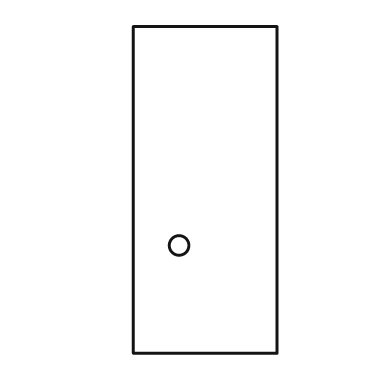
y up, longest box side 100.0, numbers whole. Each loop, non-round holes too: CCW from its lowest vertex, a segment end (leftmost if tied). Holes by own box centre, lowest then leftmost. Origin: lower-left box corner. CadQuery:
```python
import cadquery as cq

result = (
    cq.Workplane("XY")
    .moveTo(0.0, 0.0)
    .lineTo(44.0, 0.0)
    .lineTo(44.0, 100.0)
    .lineTo(0.0, 100.0)
    .close()
    .moveTo(14.0, 33.0)
    .circle(3.0)
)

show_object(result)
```